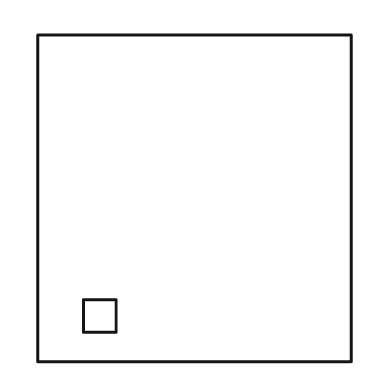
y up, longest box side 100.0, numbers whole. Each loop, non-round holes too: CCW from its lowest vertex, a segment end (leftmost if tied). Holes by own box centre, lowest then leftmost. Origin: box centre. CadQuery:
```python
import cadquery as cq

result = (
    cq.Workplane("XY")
    .moveTo(-48.0, -50.0)
    .lineTo(48.0, -50.0)
    .lineTo(48.0, 50.0)
    .lineTo(-48.0, 50.0)
    .close()
    .moveTo(-34.0, -41.0)
    .lineTo(-24.0, -41.0)
    .lineTo(-24.0, -31.0)
    .lineTo(-34.0, -31.0)
    .close()
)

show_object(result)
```